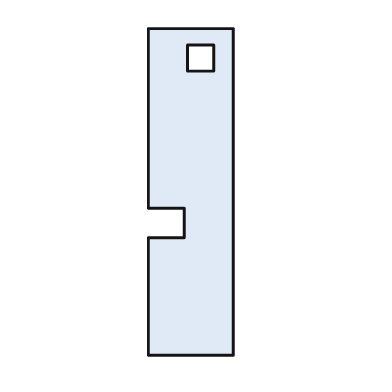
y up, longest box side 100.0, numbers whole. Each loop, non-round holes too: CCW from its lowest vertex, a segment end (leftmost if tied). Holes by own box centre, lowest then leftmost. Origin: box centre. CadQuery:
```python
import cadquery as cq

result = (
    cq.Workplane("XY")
    .moveTo(-13.0, -50.0)
    .lineTo(13.0, -50.0)
    .lineTo(13.0, 50.0)
    .lineTo(-13.0, 50.0)
    .lineTo(-13.0, -5.0)
    .lineTo(-2.0, -5.0)
    .lineTo(-2.0, -14.0)
    .lineTo(-13.0, -14.0)
    .close()
    .moveTo(-1.0, 37.0)
    .lineTo(7.0, 37.0)
    .lineTo(7.0, 45.0)
    .lineTo(-1.0, 45.0)
    .close()
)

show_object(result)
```